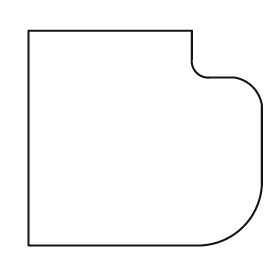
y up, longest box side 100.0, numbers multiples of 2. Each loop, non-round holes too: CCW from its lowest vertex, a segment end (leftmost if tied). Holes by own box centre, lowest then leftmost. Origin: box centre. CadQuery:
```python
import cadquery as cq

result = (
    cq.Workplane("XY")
    .moveTo(-50.0, -46.0)
    .lineTo(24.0, -46.0)
    .threePointArc((42.0, -38.0), (50.0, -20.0))
    .lineTo(50.0, 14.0)
    .threePointArc((46.0, 22.0), (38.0, 26.0))
    .lineTo(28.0, 26.0)
    .threePointArc((22.0, 28.0), (20.0, 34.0))
    .lineTo(20.0, 46.0)
    .lineTo(-50.0, 46.0)
    .close()
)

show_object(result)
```